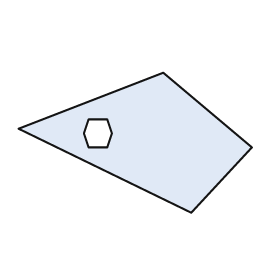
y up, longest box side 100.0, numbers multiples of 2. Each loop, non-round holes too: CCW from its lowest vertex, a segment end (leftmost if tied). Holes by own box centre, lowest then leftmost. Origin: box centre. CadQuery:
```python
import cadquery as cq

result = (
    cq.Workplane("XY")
    .moveTo(24.0, -30.0)
    .lineTo(50.0, -2.0)
    .lineTo(12.0, 30.0)
    .lineTo(-50.0, 6.0)
    .close()
    .moveTo(-20.0, -2.0)
    .lineTo(-12.0, -2.0)
    .lineTo(-10.0, 4.0)
    .lineTo(-12.0, 10.0)
    .lineTo(-20.0, 10.0)
    .lineTo(-22.0, 4.0)
    .close()
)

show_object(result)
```